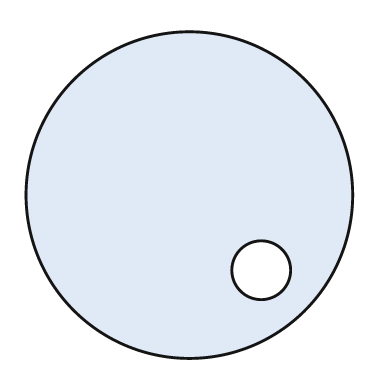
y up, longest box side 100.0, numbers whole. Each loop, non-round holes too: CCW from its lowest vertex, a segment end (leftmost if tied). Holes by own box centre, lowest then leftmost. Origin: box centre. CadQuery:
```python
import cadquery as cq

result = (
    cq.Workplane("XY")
    .moveTo(0.0, 0.0)
    .circle(50.0)
    .moveTo(22.0, -23.0)
    .circle(9.0)
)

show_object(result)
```